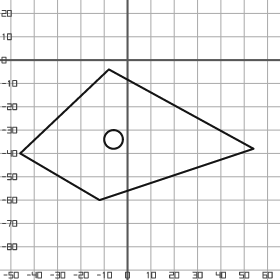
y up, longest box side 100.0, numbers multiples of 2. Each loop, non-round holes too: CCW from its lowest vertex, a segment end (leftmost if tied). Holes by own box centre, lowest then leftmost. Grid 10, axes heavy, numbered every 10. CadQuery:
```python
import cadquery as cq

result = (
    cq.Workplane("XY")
    .moveTo(-12.0, -60.0)
    .lineTo(54.0, -38.0)
    .lineTo(-8.0, -4.0)
    .lineTo(-46.0, -40.0)
    .close()
    .moveTo(-6.0, -34.0)
    .circle(4.0)
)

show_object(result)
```